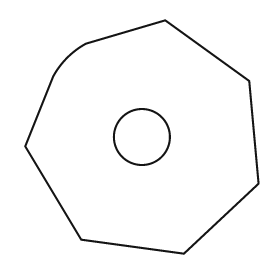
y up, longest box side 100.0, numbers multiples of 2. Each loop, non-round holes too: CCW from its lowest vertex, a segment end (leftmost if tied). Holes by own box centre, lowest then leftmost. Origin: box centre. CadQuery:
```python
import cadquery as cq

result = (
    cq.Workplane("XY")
    .moveTo(18.0, -50.0)
    .lineTo(50.0, -20.0)
    .lineTo(46.0, 24.0)
    .lineTo(10.0, 50.0)
    .lineTo(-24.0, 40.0)
    .threePointArc((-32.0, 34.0), (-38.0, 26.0))
    .lineTo(-50.0, -4.0)
    .lineTo(-26.0, -44.0)
    .close()
    .moveTo(0.0, 0.0)
    .circle(12.0)
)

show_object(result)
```